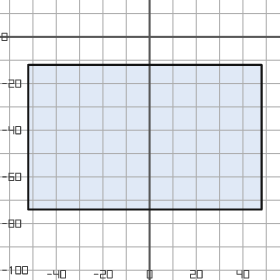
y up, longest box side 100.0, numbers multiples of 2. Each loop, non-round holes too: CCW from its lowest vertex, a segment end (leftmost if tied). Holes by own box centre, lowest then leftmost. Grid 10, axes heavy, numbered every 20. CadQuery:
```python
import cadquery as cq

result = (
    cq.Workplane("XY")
    .moveTo(-52.0, -74.0)
    .lineTo(48.0, -74.0)
    .lineTo(48.0, -12.0)
    .lineTo(-52.0, -12.0)
    .close()
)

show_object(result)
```